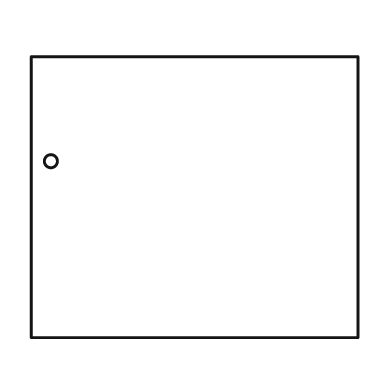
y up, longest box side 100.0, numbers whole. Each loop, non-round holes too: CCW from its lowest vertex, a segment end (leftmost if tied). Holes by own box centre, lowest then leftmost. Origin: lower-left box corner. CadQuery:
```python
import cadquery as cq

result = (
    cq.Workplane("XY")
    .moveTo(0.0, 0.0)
    .lineTo(100.0, 0.0)
    .lineTo(100.0, 86.0)
    .lineTo(0.0, 86.0)
    .close()
    .moveTo(6.0, 54.0)
    .circle(2.0)
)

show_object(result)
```